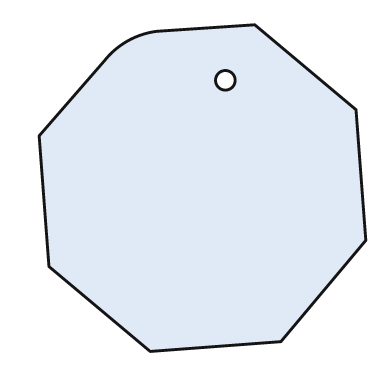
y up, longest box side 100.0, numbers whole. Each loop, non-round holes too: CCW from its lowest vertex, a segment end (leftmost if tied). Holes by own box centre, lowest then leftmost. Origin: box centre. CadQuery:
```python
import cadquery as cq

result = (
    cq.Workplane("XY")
    .moveTo(-16.0, -50.0)
    .lineTo(24.0, -47.0)
    .lineTo(50.0, -16.0)
    .lineTo(47.0, 24.0)
    .lineTo(16.0, 50.0)
    .lineTo(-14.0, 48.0)
    .threePointArc((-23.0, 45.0), (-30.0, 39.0))
    .lineTo(-50.0, 16.0)
    .lineTo(-47.0, -24.0)
    .close()
    .moveTo(7.0, 33.0)
    .circle(3.0)
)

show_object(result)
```